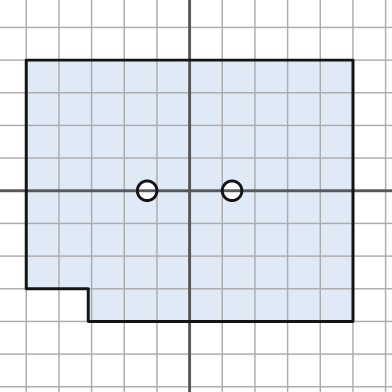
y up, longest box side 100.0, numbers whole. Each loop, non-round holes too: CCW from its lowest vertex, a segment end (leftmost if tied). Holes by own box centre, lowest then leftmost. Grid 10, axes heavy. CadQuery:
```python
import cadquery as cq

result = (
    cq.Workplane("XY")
    .moveTo(-31.0, -40.0)
    .lineTo(50.0, -40.0)
    .lineTo(50.0, 40.0)
    .lineTo(-50.0, 40.0)
    .lineTo(-50.0, -30.0)
    .lineTo(-31.0, -30.0)
    .close()
    .moveTo(-13.0, 0.0)
    .circle(3.0)
    .moveTo(13.0, 0.0)
    .circle(3.0)
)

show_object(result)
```